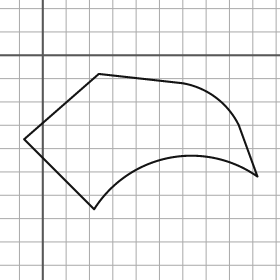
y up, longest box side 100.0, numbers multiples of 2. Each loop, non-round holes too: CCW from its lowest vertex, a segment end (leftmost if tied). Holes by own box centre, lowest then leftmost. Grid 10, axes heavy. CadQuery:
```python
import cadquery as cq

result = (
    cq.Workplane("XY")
    .moveTo(22.0, -66.0)
    .threePointArc((54.0, -44.0), (92.0, -52.0))
    .lineTo(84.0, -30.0)
    .threePointArc((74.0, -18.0), (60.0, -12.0))
    .lineTo(24.0, -8.0)
    .lineTo(-8.0, -36.0)
    .close()
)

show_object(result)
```